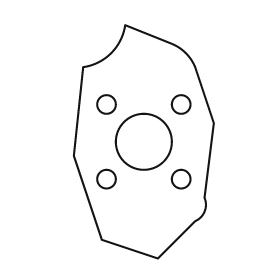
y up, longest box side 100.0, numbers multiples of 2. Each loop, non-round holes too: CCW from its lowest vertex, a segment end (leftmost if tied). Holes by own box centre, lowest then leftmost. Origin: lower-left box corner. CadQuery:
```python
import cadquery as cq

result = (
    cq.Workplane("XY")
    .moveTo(36.0, 0.0)
    .lineTo(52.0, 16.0)
    .threePointArc((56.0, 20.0), (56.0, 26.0))
    .lineTo(60.0, 58.0)
    .lineTo(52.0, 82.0)
    .threePointArc((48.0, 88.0), (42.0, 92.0))
    .lineTo(22.0, 100.0)
    .threePointArc((16.0, 88.0), (4.0, 82.0))
    .lineTo(0.0, 44.0)
    .lineTo(12.0, 8.0)
    .close()
    .moveTo(14.0, 34.0)
    .circle(4.0)
    .moveTo(46.0, 34.0)
    .circle(4.0)
    .moveTo(30.0, 50.0)
    .circle(12.0)
    .moveTo(14.0, 66.0)
    .circle(4.0)
    .moveTo(46.0, 66.0)
    .circle(4.0)
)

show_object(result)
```